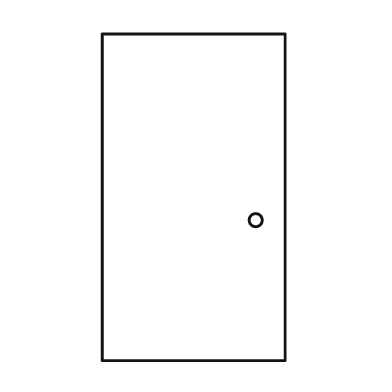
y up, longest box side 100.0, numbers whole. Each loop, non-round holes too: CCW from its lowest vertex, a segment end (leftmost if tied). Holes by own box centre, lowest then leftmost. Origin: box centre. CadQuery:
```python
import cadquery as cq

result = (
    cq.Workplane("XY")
    .moveTo(-28.0, -50.0)
    .lineTo(28.0, -50.0)
    .lineTo(28.0, 50.0)
    .lineTo(-28.0, 50.0)
    .close()
    .moveTo(19.0, -7.0)
    .circle(2.0)
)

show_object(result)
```